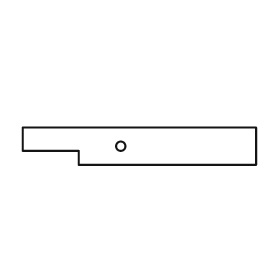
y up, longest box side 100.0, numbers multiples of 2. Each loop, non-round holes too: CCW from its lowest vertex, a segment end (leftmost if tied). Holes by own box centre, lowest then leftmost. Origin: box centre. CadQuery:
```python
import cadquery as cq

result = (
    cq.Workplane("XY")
    .moveTo(-26.0, -8.0)
    .lineTo(50.0, -8.0)
    .lineTo(50.0, 8.0)
    .lineTo(-50.0, 8.0)
    .lineTo(-50.0, -2.0)
    .lineTo(-26.0, -2.0)
    .close()
    .moveTo(-8.0, 0.0)
    .circle(2.0)
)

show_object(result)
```